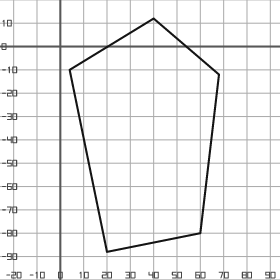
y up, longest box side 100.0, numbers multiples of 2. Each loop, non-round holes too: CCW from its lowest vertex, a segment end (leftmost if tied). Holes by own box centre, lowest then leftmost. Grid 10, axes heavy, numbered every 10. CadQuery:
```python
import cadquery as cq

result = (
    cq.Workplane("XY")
    .moveTo(20.0, -88.0)
    .lineTo(60.0, -80.0)
    .lineTo(68.0, -12.0)
    .lineTo(40.0, 12.0)
    .lineTo(4.0, -10.0)
    .close()
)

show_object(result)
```